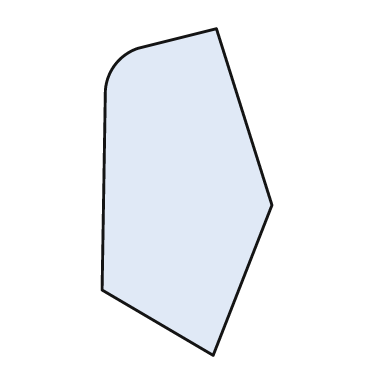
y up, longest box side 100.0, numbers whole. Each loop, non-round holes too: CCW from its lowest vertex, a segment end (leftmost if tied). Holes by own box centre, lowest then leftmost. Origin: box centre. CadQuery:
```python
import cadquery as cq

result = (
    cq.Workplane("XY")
    .moveTo(8.0, -50.0)
    .lineTo(26.0, -4.0)
    .lineTo(9.0, 50.0)
    .lineTo(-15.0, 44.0)
    .threePointArc((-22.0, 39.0), (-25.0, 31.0))
    .lineTo(-26.0, -30.0)
    .close()
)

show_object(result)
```